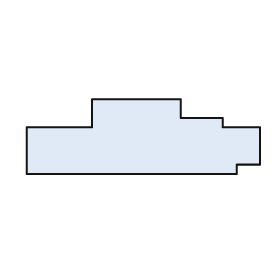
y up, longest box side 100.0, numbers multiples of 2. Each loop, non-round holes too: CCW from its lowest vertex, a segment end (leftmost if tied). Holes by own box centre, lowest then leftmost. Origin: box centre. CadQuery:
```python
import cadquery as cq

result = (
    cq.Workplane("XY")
    .moveTo(-50.0, -16.0)
    .lineTo(40.0, -16.0)
    .lineTo(40.0, -12.0)
    .lineTo(50.0, -12.0)
    .lineTo(50.0, 4.0)
    .lineTo(34.0, 4.0)
    .lineTo(34.0, 8.0)
    .lineTo(16.0, 8.0)
    .lineTo(16.0, 16.0)
    .lineTo(-22.0, 16.0)
    .lineTo(-22.0, 4.0)
    .lineTo(-50.0, 4.0)
    .close()
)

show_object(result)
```